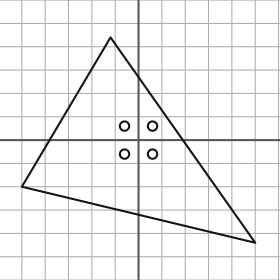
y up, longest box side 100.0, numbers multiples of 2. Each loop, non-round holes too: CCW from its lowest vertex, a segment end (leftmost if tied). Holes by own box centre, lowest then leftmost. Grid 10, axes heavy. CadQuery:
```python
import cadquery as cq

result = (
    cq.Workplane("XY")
    .moveTo(50.0, -44.0)
    .lineTo(-12.0, 44.0)
    .lineTo(-50.0, -20.0)
    .close()
    .moveTo(-6.0, -6.0)
    .circle(2.0)
    .moveTo(6.0, -6.0)
    .circle(2.0)
    .moveTo(-6.0, 6.0)
    .circle(2.0)
    .moveTo(6.0, 6.0)
    .circle(2.0)
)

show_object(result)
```